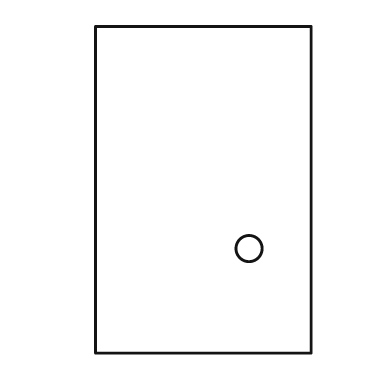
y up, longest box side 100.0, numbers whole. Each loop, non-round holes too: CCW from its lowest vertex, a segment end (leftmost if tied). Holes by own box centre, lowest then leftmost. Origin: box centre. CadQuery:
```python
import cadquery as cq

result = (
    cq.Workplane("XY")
    .moveTo(-33.0, -50.0)
    .lineTo(33.0, -50.0)
    .lineTo(33.0, 50.0)
    .lineTo(-33.0, 50.0)
    .close()
    .moveTo(14.0, -18.0)
    .circle(4.0)
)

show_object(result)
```